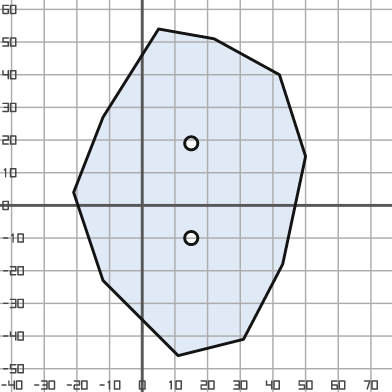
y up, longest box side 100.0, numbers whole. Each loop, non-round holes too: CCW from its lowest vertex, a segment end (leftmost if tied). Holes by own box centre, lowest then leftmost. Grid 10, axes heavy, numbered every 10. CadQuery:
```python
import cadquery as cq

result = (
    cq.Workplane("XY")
    .moveTo(11.0, -46.0)
    .lineTo(31.0, -41.0)
    .lineTo(43.0, -18.0)
    .lineTo(50.0, 15.0)
    .lineTo(42.0, 40.0)
    .lineTo(22.0, 51.0)
    .lineTo(5.0, 54.0)
    .lineTo(-12.0, 27.0)
    .lineTo(-21.0, 4.0)
    .lineTo(-12.0, -23.0)
    .close()
    .moveTo(15.0, -10.0)
    .circle(2.0)
    .moveTo(15.0, 19.0)
    .circle(2.0)
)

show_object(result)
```